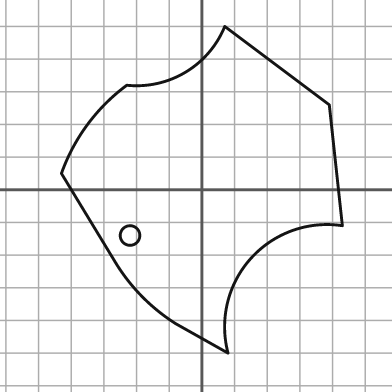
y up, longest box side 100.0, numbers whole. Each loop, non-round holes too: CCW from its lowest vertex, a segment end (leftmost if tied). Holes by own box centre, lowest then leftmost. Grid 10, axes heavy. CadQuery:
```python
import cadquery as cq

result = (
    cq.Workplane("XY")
    .moveTo(8.0, -50.0)
    .threePointArc((15.0, -21.0), (43.0, -11.0))
    .lineTo(39.0, 26.0)
    .lineTo(7.0, 50.0)
    .threePointArc((-5.0, 36.0), (-23.0, 32.0))
    .threePointArc((-35.0, 20.0), (-43.0, 5.0))
    .lineTo(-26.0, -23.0)
    .threePointArc((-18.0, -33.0), (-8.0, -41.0))
    .close()
    .moveTo(-22.0, -14.0)
    .circle(3.0)
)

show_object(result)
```